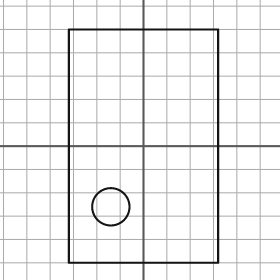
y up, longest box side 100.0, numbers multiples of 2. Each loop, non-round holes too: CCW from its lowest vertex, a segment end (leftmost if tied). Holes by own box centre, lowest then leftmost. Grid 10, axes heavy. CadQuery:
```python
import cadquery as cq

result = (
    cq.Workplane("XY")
    .moveTo(-32.0, -50.0)
    .lineTo(32.0, -50.0)
    .lineTo(32.0, 50.0)
    .lineTo(-32.0, 50.0)
    .close()
    .moveTo(-14.0, -26.0)
    .circle(8.0)
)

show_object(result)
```